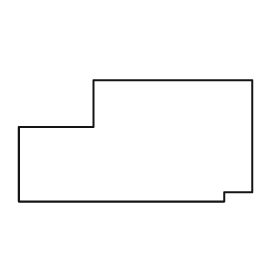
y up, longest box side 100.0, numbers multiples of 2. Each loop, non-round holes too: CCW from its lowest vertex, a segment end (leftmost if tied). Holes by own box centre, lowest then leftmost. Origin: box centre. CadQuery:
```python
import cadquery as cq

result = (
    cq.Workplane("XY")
    .moveTo(-50.0, -26.0)
    .lineTo(38.0, -26.0)
    .lineTo(38.0, -22.0)
    .lineTo(50.0, -22.0)
    .lineTo(50.0, 26.0)
    .lineTo(-18.0, 26.0)
    .lineTo(-18.0, 6.0)
    .lineTo(-50.0, 6.0)
    .close()
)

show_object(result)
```